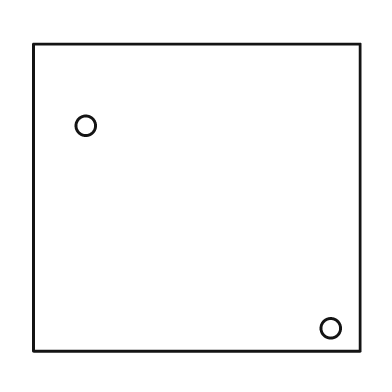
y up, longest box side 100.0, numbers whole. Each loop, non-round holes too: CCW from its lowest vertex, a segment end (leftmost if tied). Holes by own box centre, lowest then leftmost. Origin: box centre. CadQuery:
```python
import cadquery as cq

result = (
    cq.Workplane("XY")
    .moveTo(-50.0, -47.0)
    .lineTo(50.0, -47.0)
    .lineTo(50.0, 47.0)
    .lineTo(-50.0, 47.0)
    .close()
    .moveTo(41.0, -40.0)
    .circle(3.0)
    .moveTo(-34.0, 22.0)
    .circle(3.0)
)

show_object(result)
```